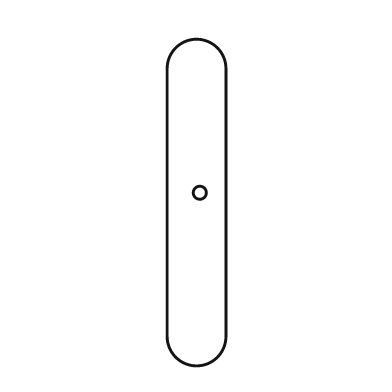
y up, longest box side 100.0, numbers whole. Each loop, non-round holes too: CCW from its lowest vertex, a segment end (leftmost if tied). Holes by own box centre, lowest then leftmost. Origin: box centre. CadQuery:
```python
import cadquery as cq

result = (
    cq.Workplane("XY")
    .moveTo(-9.0, -41.0)
    .threePointArc((0.0, -50.0), (9.0, -41.0))
    .lineTo(9.0, 41.0)
    .threePointArc((0.0, 50.0), (-9.0, 41.0))
    .close()
    .moveTo(1.0, 3.0)
    .circle(2.0)
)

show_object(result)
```